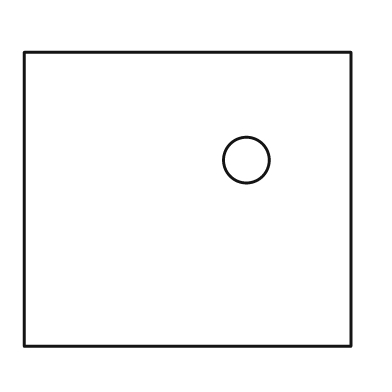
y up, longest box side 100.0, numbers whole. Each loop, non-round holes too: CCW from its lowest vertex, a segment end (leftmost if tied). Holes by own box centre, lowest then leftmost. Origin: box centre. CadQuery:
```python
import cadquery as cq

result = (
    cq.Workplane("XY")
    .moveTo(-50.0, -45.0)
    .lineTo(50.0, -45.0)
    .lineTo(50.0, 45.0)
    .lineTo(-50.0, 45.0)
    .close()
    .moveTo(18.0, 12.0)
    .circle(7.0)
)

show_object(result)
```